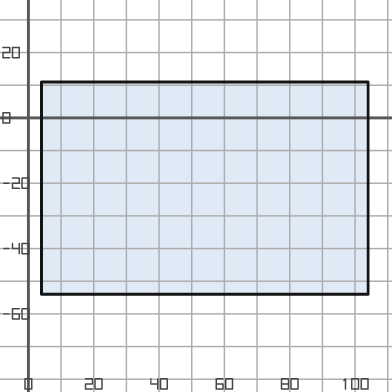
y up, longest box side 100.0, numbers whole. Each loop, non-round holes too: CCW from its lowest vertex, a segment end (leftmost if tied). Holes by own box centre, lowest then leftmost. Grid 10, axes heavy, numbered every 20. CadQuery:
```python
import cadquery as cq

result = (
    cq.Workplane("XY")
    .moveTo(4.0, -54.0)
    .lineTo(104.0, -54.0)
    .lineTo(104.0, 11.0)
    .lineTo(4.0, 11.0)
    .close()
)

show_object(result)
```